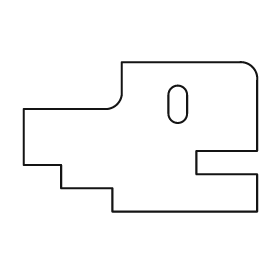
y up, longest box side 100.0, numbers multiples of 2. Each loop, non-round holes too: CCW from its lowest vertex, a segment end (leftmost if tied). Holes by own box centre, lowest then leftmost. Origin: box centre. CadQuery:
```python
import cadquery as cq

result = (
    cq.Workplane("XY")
    .moveTo(-12.0, -32.0)
    .lineTo(50.0, -32.0)
    .lineTo(50.0, -16.0)
    .lineTo(24.0, -16.0)
    .lineTo(24.0, -6.0)
    .lineTo(50.0, -6.0)
    .lineTo(50.0, 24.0)
    .threePointArc((48.0, 30.0), (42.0, 32.0))
    .lineTo(-8.0, 32.0)
    .lineTo(-8.0, 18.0)
    .threePointArc((-10.0, 14.0), (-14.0, 12.0))
    .lineTo(-50.0, 12.0)
    .lineTo(-50.0, -12.0)
    .lineTo(-34.0, -12.0)
    .lineTo(-34.0, -22.0)
    .lineTo(-12.0, -22.0)
    .close()
    .moveTo(12.0, 10.0)
    .threePointArc((16.0, 6.0), (20.0, 10.0))
    .lineTo(20.0, 18.0)
    .threePointArc((16.0, 22.0), (12.0, 18.0))
    .close()
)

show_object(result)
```